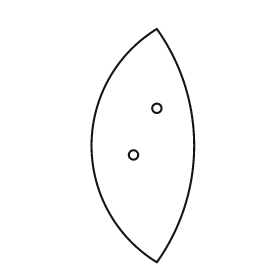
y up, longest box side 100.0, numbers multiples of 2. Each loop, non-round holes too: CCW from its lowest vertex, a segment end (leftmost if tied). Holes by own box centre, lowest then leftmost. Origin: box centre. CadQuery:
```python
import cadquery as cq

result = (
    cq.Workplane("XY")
    .moveTo(6.0, -50.0)
    .threePointArc((22.0, 0.0), (6.0, 50.0))
    .threePointArc((-22.0, 0.0), (6.0, -50.0))
    .close()
    .moveTo(-4.0, -4.0)
    .circle(2.0)
    .moveTo(6.0, 16.0)
    .circle(2.0)
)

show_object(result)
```